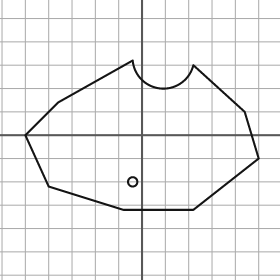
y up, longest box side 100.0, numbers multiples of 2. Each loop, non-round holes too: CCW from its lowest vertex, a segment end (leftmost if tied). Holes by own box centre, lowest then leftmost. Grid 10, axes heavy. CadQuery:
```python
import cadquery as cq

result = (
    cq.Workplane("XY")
    .moveTo(-8.0, -32.0)
    .lineTo(22.0, -32.0)
    .lineTo(50.0, -10.0)
    .lineTo(44.0, 10.0)
    .lineTo(22.0, 30.0)
    .threePointArc((8.0, 20.0), (-4.0, 32.0))
    .lineTo(-36.0, 14.0)
    .lineTo(-50.0, 0.0)
    .lineTo(-40.0, -22.0)
    .close()
    .moveTo(-4.0, -20.0)
    .circle(2.0)
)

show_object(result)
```